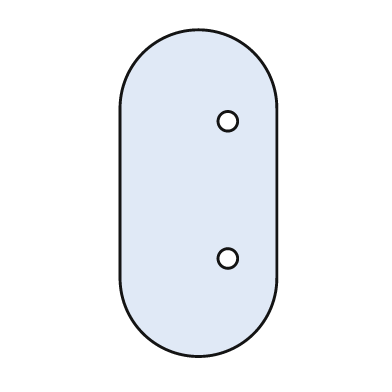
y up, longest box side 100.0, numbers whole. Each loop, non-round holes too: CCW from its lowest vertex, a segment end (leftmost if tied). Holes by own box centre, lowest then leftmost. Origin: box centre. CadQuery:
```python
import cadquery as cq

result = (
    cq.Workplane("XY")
    .moveTo(-24.0, -26.0)
    .threePointArc((0.0, -50.0), (24.0, -26.0))
    .lineTo(24.0, 26.0)
    .threePointArc((0.0, 50.0), (-24.0, 26.0))
    .close()
    .moveTo(9.0, -20.0)
    .circle(3.0)
    .moveTo(9.0, 22.0)
    .circle(3.0)
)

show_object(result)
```